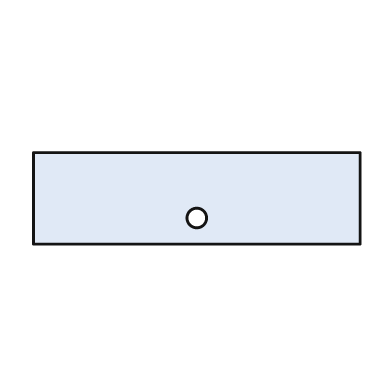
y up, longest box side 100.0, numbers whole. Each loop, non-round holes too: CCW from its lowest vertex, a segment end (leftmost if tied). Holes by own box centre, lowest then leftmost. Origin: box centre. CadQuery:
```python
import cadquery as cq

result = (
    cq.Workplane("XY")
    .moveTo(-50.0, -14.0)
    .lineTo(50.0, -14.0)
    .lineTo(50.0, 14.0)
    .lineTo(-50.0, 14.0)
    .close()
    .moveTo(0.0, -6.0)
    .circle(3.0)
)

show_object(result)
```